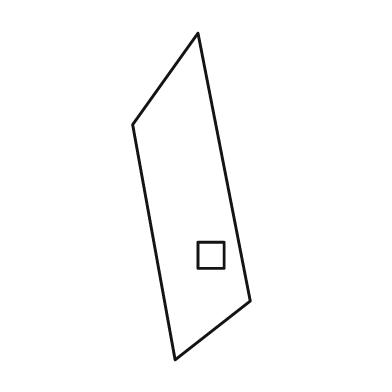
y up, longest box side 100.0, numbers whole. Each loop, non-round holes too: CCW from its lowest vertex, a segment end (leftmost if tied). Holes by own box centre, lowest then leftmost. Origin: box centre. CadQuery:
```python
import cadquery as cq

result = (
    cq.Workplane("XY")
    .moveTo(-5.0, -50.0)
    .lineTo(18.0, -32.0)
    .lineTo(2.0, 50.0)
    .lineTo(-18.0, 22.0)
    .close()
    .moveTo(2.0, -22.0)
    .lineTo(10.0, -22.0)
    .lineTo(10.0, -14.0)
    .lineTo(2.0, -14.0)
    .close()
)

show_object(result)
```